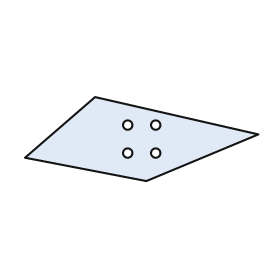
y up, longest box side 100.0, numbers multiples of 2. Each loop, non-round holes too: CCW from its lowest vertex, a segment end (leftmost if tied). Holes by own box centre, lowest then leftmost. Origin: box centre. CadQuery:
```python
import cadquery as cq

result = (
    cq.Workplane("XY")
    .moveTo(2.0, -18.0)
    .lineTo(50.0, 2.0)
    .lineTo(-20.0, 18.0)
    .lineTo(-50.0, -8.0)
    .close()
    .moveTo(-6.0, -6.0)
    .circle(2.0)
    .moveTo(6.0, -6.0)
    .circle(2.0)
    .moveTo(-6.0, 6.0)
    .circle(2.0)
    .moveTo(6.0, 6.0)
    .circle(2.0)
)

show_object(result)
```